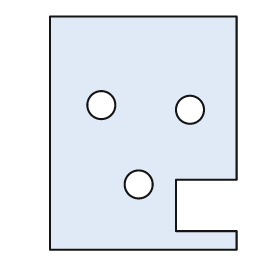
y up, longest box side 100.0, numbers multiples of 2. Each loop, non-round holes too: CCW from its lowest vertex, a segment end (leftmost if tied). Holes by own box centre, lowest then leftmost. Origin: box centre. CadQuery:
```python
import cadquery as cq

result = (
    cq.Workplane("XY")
    .moveTo(-40.0, -50.0)
    .lineTo(40.0, -50.0)
    .lineTo(40.0, -42.0)
    .lineTo(14.0, -42.0)
    .lineTo(14.0, -20.0)
    .lineTo(40.0, -20.0)
    .lineTo(40.0, 50.0)
    .lineTo(-40.0, 50.0)
    .close()
    .moveTo(-2.0, -22.0)
    .circle(6.0)
    .moveTo(20.0, 10.0)
    .circle(6.0)
    .moveTo(-18.0, 12.0)
    .circle(6.0)
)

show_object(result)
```